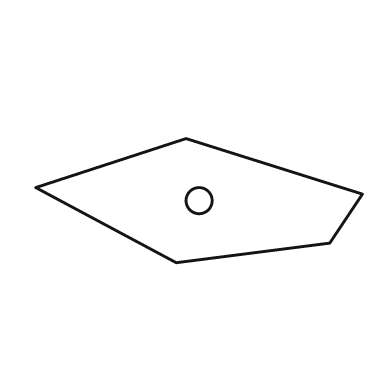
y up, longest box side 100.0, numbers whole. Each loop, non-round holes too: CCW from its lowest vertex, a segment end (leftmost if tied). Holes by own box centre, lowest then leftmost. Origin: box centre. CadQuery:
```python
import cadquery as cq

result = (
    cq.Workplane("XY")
    .moveTo(-7.0, -19.0)
    .lineTo(40.0, -13.0)
    .lineTo(50.0, 2.0)
    .lineTo(-4.0, 19.0)
    .lineTo(-50.0, 4.0)
    .close()
    .moveTo(0.0, 0.0)
    .circle(4.0)
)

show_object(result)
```